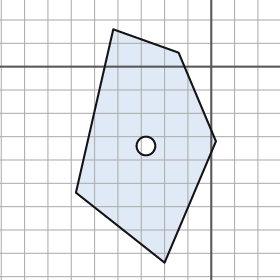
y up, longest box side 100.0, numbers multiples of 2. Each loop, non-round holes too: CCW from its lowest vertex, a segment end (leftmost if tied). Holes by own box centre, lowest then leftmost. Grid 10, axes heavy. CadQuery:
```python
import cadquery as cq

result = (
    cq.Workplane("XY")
    .moveTo(-20.0, -84.0)
    .lineTo(2.0, -32.0)
    .lineTo(-14.0, 6.0)
    .lineTo(-42.0, 16.0)
    .lineTo(-58.0, -54.0)
    .close()
    .moveTo(-28.0, -34.0)
    .circle(4.0)
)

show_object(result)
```